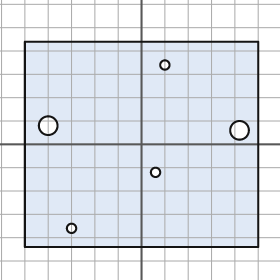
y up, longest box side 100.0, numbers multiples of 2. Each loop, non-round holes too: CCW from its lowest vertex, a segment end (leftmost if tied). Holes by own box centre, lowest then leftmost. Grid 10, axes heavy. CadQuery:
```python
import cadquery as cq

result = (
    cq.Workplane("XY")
    .moveTo(-50.0, -44.0)
    .lineTo(50.0, -44.0)
    .lineTo(50.0, 44.0)
    .lineTo(-50.0, 44.0)
    .close()
    .moveTo(-30.0, -36.0)
    .circle(2.0)
    .moveTo(6.0, -12.0)
    .circle(2.0)
    .moveTo(42.0, 6.0)
    .circle(4.0)
    .moveTo(-40.0, 8.0)
    .circle(4.0)
    .moveTo(10.0, 34.0)
    .circle(2.0)
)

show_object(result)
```